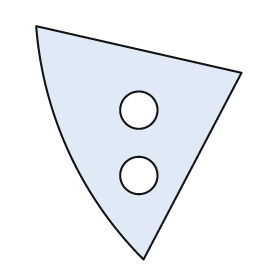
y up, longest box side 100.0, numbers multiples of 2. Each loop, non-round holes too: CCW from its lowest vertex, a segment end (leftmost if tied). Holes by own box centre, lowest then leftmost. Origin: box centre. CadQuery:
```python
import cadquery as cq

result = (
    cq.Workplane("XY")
    .moveTo(2.0, -50.0)
    .lineTo(44.0, 30.0)
    .lineTo(-44.0, 50.0)
    .threePointArc((-30.0, -4.0), (2.0, -50.0))
    .close()
    .moveTo(0.0, -14.0)
    .circle(8.0)
    .moveTo(0.0, 14.0)
    .circle(8.0)
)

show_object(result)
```